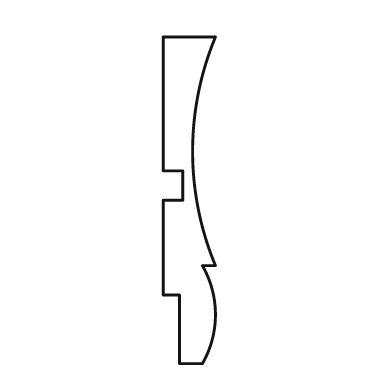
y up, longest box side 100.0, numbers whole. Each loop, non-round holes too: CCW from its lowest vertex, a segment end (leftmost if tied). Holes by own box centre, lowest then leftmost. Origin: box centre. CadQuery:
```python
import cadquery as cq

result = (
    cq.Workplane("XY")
    .moveTo(-3.0, -50.0)
    .lineTo(4.0, -50.0)
    .threePointArc((8.0, -35.0), (4.0, -20.0))
    .lineTo(8.0, -20.0)
    .threePointArc((1.0, 15.0), (8.0, 50.0))
    .lineTo(-8.0, 50.0)
    .lineTo(-8.0, 9.0)
    .lineTo(-2.0, 9.0)
    .lineTo(-2.0, 0.0)
    .lineTo(-8.0, 0.0)
    .lineTo(-8.0, -29.0)
    .lineTo(-3.0, -29.0)
    .close()
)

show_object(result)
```